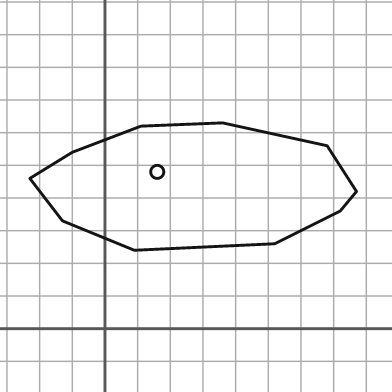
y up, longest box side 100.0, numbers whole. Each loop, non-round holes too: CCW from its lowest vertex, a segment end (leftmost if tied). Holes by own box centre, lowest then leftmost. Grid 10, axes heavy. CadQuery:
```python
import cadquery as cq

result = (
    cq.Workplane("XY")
    .moveTo(9.0, 24.0)
    .lineTo(52.0, 26.0)
    .lineTo(72.0, 36.0)
    .lineTo(77.0, 42.0)
    .lineTo(68.0, 56.0)
    .lineTo(36.0, 63.0)
    .lineTo(11.0, 62.0)
    .lineTo(-10.0, 54.0)
    .lineTo(-23.0, 46.0)
    .lineTo(-13.0, 33.0)
    .close()
    .moveTo(16.0, 48.0)
    .circle(2.0)
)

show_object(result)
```